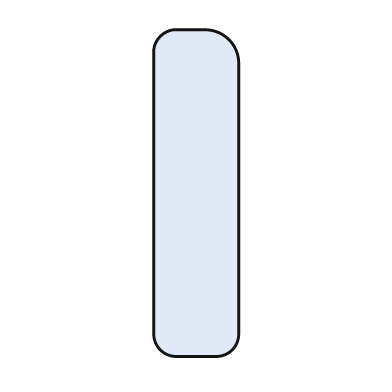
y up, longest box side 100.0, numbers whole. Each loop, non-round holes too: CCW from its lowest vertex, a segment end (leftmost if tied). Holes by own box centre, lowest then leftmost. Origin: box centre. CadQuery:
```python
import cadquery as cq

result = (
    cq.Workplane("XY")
    .moveTo(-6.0, -50.0)
    .lineTo(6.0, -50.0)
    .threePointArc((11.0, -48.0), (13.0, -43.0))
    .lineTo(13.0, 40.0)
    .threePointArc((10.0, 47.0), (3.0, 50.0))
    .lineTo(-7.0, 50.0)
    .threePointArc((-11.0, 48.0), (-13.0, 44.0))
    .lineTo(-13.0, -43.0)
    .threePointArc((-11.0, -48.0), (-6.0, -50.0))
    .close()
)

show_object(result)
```